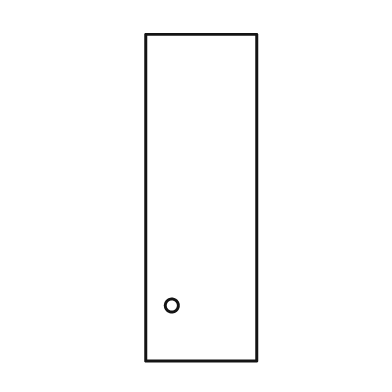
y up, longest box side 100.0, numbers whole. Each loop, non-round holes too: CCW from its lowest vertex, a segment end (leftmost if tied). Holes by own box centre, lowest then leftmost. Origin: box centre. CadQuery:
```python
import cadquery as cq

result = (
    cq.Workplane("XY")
    .moveTo(-17.0, -50.0)
    .lineTo(17.0, -50.0)
    .lineTo(17.0, 50.0)
    .lineTo(-17.0, 50.0)
    .close()
    .moveTo(-9.0, -33.0)
    .circle(2.0)
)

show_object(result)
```